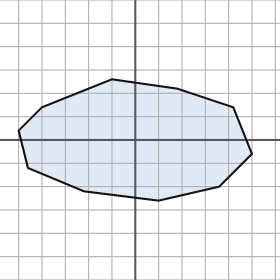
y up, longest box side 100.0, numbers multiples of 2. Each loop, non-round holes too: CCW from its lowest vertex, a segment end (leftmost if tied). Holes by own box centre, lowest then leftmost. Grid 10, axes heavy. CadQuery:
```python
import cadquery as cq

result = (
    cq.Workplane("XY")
    .moveTo(10.0, -26.0)
    .lineTo(36.0, -20.0)
    .lineTo(50.0, -6.0)
    .lineTo(42.0, 14.0)
    .lineTo(18.0, 22.0)
    .lineTo(-10.0, 26.0)
    .lineTo(-40.0, 14.0)
    .lineTo(-50.0, 4.0)
    .lineTo(-46.0, -12.0)
    .lineTo(-22.0, -22.0)
    .close()
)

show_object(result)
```